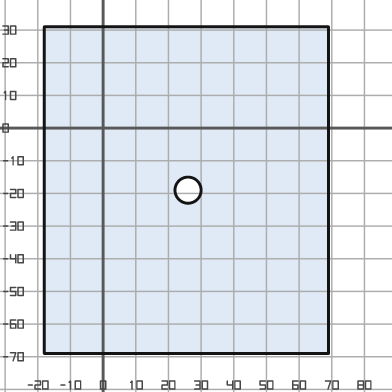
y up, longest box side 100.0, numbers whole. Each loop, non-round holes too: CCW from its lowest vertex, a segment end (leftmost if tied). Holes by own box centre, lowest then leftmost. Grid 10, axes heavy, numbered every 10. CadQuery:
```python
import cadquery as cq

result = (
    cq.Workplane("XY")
    .moveTo(-18.0, -69.0)
    .lineTo(69.0, -69.0)
    .lineTo(69.0, 31.0)
    .lineTo(-18.0, 31.0)
    .close()
    .moveTo(26.0, -19.0)
    .circle(4.0)
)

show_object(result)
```